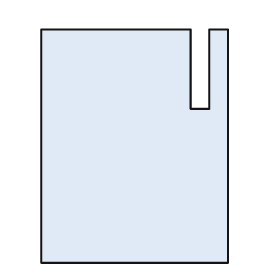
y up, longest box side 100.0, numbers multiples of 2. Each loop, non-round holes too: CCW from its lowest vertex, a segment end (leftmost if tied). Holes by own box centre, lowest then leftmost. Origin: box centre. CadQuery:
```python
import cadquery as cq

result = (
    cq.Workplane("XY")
    .moveTo(-40.0, -50.0)
    .lineTo(40.0, -50.0)
    .lineTo(40.0, 50.0)
    .lineTo(32.0, 50.0)
    .lineTo(32.0, 16.0)
    .lineTo(24.0, 16.0)
    .lineTo(24.0, 50.0)
    .lineTo(-40.0, 50.0)
    .close()
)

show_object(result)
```